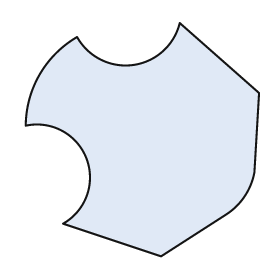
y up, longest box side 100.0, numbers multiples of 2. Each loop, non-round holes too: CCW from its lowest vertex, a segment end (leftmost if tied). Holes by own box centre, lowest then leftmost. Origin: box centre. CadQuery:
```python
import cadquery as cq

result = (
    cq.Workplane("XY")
    .moveTo(8.0, -50.0)
    .lineTo(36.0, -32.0)
    .threePointArc((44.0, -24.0), (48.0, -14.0))
    .lineTo(50.0, 20.0)
    .lineTo(16.0, 50.0)
    .threePointArc((-4.0, 32.0), (-28.0, 44.0))
    .threePointArc((-44.0, 28.0), (-50.0, 6.0))
    .threePointArc((-24.0, -8.0), (-34.0, -36.0))
    .close()
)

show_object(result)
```